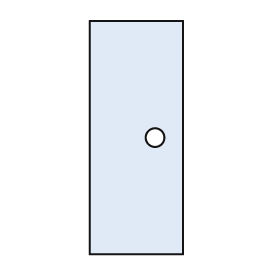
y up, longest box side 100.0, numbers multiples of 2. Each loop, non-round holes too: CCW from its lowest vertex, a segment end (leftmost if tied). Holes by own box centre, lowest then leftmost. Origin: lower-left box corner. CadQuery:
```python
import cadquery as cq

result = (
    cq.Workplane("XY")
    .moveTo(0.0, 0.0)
    .lineTo(40.0, 0.0)
    .lineTo(40.0, 100.0)
    .lineTo(0.0, 100.0)
    .close()
    .moveTo(28.0, 50.0)
    .circle(4.0)
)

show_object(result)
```